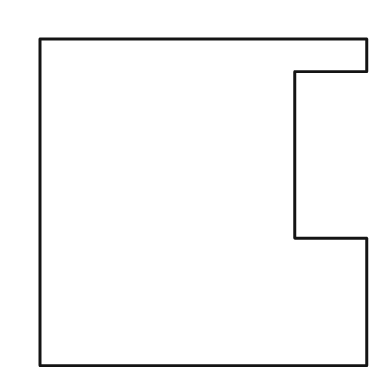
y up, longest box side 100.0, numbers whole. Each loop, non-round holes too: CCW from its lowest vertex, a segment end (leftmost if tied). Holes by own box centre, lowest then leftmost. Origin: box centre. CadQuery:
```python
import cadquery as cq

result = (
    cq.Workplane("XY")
    .moveTo(-50.0, -50.0)
    .lineTo(50.0, -50.0)
    .lineTo(50.0, -11.0)
    .lineTo(28.0, -11.0)
    .lineTo(28.0, 40.0)
    .lineTo(50.0, 40.0)
    .lineTo(50.0, 50.0)
    .lineTo(-50.0, 50.0)
    .close()
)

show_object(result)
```